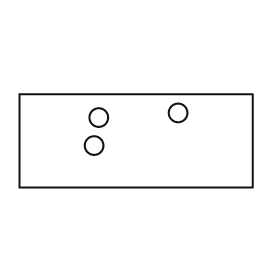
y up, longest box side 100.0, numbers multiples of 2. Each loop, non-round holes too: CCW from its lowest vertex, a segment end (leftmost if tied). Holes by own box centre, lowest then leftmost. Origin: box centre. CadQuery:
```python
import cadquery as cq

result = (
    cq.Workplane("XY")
    .moveTo(-50.0, -20.0)
    .lineTo(50.0, -20.0)
    .lineTo(50.0, 20.0)
    .lineTo(-50.0, 20.0)
    .close()
    .moveTo(-18.0, -2.0)
    .circle(4.0)
    .moveTo(-16.0, 10.0)
    .circle(4.0)
    .moveTo(18.0, 12.0)
    .circle(4.0)
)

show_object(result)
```